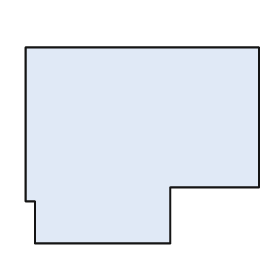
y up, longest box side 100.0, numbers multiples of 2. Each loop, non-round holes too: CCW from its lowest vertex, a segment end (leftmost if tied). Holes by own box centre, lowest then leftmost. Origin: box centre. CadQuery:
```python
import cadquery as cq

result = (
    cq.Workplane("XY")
    .moveTo(-46.0, -42.0)
    .lineTo(12.0, -42.0)
    .lineTo(12.0, -18.0)
    .lineTo(50.0, -18.0)
    .lineTo(50.0, 42.0)
    .lineTo(-50.0, 42.0)
    .lineTo(-50.0, -24.0)
    .lineTo(-46.0, -24.0)
    .close()
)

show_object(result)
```